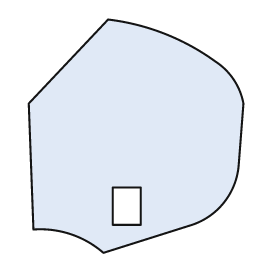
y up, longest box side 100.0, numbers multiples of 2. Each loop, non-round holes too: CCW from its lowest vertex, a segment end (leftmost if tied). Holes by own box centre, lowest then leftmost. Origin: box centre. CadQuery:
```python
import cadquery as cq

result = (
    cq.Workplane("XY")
    .moveTo(-14.0, -50.0)
    .lineTo(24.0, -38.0)
    .threePointArc((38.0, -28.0), (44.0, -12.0))
    .lineTo(46.0, 14.0)
    .threePointArc((42.0, 24.0), (34.0, 32.0))
    .threePointArc((12.0, 44.0), (-12.0, 50.0))
    .lineTo(-46.0, 14.0)
    .lineTo(-44.0, -40.0)
    .threePointArc((-28.0, -42.0), (-14.0, -50.0))
    .close()
    .moveTo(-10.0, -38.0)
    .lineTo(2.0, -38.0)
    .lineTo(2.0, -22.0)
    .lineTo(-10.0, -22.0)
    .close()
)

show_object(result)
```